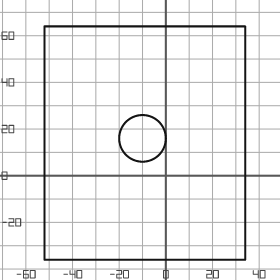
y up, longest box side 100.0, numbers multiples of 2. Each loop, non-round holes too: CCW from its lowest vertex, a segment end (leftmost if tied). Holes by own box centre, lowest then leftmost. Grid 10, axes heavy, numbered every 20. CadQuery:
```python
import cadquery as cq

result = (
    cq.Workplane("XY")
    .moveTo(-52.0, -36.0)
    .lineTo(34.0, -36.0)
    .lineTo(34.0, 64.0)
    .lineTo(-52.0, 64.0)
    .close()
    .moveTo(-10.0, 16.0)
    .circle(10.0)
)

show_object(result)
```